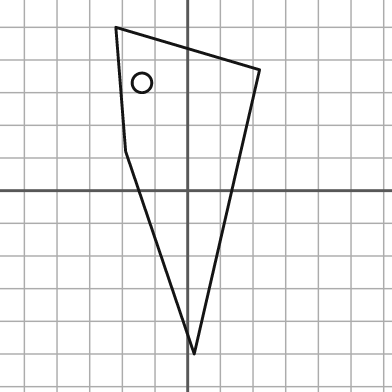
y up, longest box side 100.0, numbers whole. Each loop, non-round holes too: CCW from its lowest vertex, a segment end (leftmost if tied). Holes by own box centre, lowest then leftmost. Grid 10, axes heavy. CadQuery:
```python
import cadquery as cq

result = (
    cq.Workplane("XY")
    .moveTo(2.0, -50.0)
    .lineTo(22.0, 37.0)
    .lineTo(-22.0, 50.0)
    .lineTo(-19.0, 12.0)
    .close()
    .moveTo(-14.0, 33.0)
    .circle(3.0)
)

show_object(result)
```